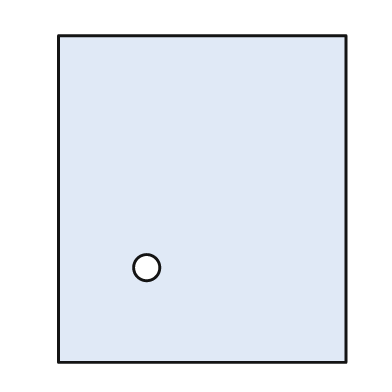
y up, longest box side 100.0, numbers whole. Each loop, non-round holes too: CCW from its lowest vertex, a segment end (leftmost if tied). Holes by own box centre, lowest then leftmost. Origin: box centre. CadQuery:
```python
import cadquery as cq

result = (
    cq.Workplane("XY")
    .moveTo(-44.0, -50.0)
    .lineTo(44.0, -50.0)
    .lineTo(44.0, 50.0)
    .lineTo(-44.0, 50.0)
    .close()
    .moveTo(-17.0, -21.0)
    .circle(4.0)
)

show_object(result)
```